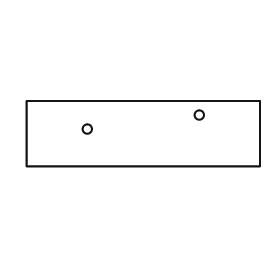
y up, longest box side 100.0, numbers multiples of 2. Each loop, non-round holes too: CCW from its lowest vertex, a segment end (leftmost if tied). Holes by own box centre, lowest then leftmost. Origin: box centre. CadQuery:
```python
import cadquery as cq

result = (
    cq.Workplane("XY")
    .moveTo(-50.0, -14.0)
    .lineTo(50.0, -14.0)
    .lineTo(50.0, 14.0)
    .lineTo(-50.0, 14.0)
    .close()
    .moveTo(-24.0, 2.0)
    .circle(2.0)
    .moveTo(24.0, 8.0)
    .circle(2.0)
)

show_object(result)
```